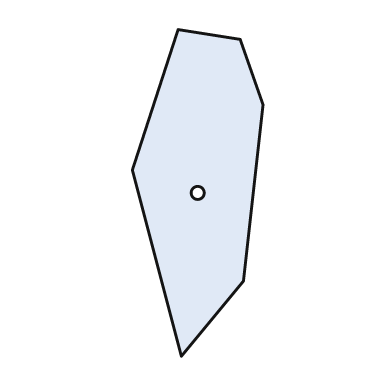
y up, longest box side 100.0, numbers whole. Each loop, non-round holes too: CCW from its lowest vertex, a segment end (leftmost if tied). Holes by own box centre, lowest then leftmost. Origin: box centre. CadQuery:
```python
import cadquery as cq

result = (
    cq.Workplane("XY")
    .moveTo(-5.0, -50.0)
    .lineTo(14.0, -27.0)
    .lineTo(20.0, 27.0)
    .lineTo(13.0, 47.0)
    .lineTo(-6.0, 50.0)
    .lineTo(-20.0, 7.0)
    .close()
    .moveTo(0.0, 0.0)
    .circle(2.0)
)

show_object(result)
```